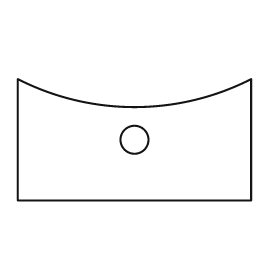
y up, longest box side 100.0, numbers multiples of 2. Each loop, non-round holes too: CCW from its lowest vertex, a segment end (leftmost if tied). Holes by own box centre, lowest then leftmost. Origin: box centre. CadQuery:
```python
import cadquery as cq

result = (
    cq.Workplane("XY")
    .moveTo(-50.0, -26.0)
    .lineTo(50.0, -26.0)
    .lineTo(50.0, 26.0)
    .threePointArc((0.0, 14.0), (-50.0, 26.0))
    .close()
    .moveTo(0.0, 0.0)
    .circle(6.0)
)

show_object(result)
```